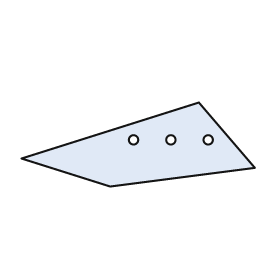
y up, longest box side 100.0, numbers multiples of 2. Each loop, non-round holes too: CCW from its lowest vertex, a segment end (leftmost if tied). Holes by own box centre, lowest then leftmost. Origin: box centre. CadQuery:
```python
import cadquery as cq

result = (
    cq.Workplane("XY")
    .moveTo(-12.0, -18.0)
    .lineTo(50.0, -10.0)
    .lineTo(26.0, 18.0)
    .lineTo(-50.0, -6.0)
    .close()
    .moveTo(-2.0, 2.0)
    .circle(2.0)
    .moveTo(14.0, 2.0)
    .circle(2.0)
    .moveTo(30.0, 2.0)
    .circle(2.0)
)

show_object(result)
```